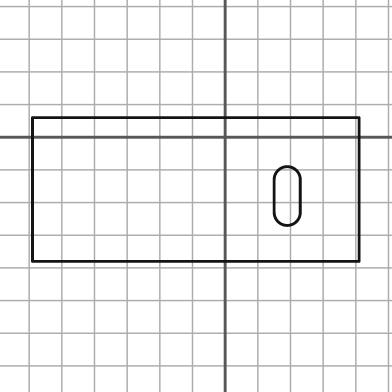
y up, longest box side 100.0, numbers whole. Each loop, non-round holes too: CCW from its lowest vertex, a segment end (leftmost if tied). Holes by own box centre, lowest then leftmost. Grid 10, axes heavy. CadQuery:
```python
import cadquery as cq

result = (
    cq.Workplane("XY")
    .moveTo(-59.0, -38.0)
    .lineTo(41.0, -38.0)
    .lineTo(41.0, 6.0)
    .lineTo(-59.0, 6.0)
    .close()
    .moveTo(15.0, -23.0)
    .threePointArc((19.0, -27.0), (23.0, -23.0))
    .lineTo(23.0, -13.0)
    .threePointArc((19.0, -9.0), (15.0, -13.0))
    .close()
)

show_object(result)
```